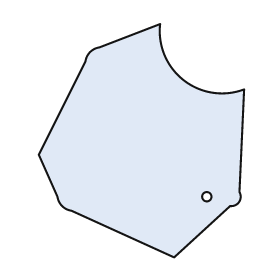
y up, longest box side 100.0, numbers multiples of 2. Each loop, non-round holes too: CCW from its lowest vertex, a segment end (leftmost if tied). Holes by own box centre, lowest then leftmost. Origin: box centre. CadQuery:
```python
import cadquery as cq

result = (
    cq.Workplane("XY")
    .moveTo(14.0, -50.0)
    .lineTo(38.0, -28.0)
    .threePointArc((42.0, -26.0), (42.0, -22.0))
    .lineTo(44.0, 22.0)
    .threePointArc((18.0, 26.0), (8.0, 50.0))
    .lineTo(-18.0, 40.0)
    .threePointArc((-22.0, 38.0), (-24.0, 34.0))
    .lineTo(-44.0, -6.0)
    .lineTo(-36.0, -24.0)
    .threePointArc((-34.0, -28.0), (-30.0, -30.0))
    .close()
    .moveTo(28.0, -24.0)
    .circle(2.0)
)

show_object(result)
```